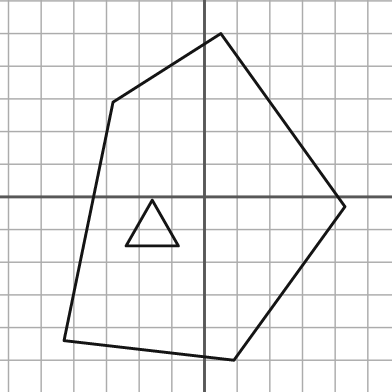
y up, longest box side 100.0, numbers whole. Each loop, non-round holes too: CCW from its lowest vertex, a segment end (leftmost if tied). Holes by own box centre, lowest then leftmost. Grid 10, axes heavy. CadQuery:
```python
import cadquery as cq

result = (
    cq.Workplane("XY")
    .moveTo(9.0, -50.0)
    .lineTo(43.0, -3.0)
    .lineTo(5.0, 50.0)
    .lineTo(-28.0, 29.0)
    .lineTo(-43.0, -44.0)
    .close()
    .moveTo(-24.0, -15.0)
    .lineTo(-8.0, -15.0)
    .lineTo(-16.0, -1.0)
    .close()
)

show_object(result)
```